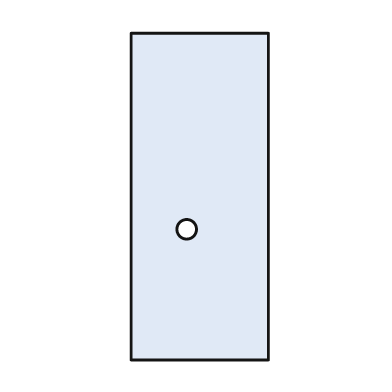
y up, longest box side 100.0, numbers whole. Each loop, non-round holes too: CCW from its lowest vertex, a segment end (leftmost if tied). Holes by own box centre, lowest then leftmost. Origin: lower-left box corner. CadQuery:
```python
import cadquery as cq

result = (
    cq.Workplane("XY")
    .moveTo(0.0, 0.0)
    .lineTo(42.0, 0.0)
    .lineTo(42.0, 100.0)
    .lineTo(0.0, 100.0)
    .close()
    .moveTo(17.0, 40.0)
    .circle(3.0)
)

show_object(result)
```